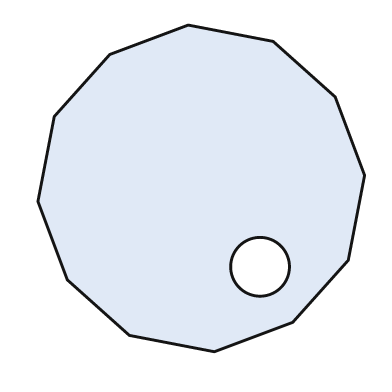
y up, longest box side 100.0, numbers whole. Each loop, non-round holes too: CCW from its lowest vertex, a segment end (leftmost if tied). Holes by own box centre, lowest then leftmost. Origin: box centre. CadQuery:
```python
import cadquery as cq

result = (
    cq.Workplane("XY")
    .moveTo(4.0, -50.0)
    .lineTo(28.0, -41.0)
    .lineTo(45.0, -22.0)
    .lineTo(50.0, 4.0)
    .lineTo(41.0, 28.0)
    .lineTo(22.0, 45.0)
    .lineTo(-4.0, 50.0)
    .lineTo(-28.0, 41.0)
    .lineTo(-45.0, 22.0)
    .lineTo(-50.0, -4.0)
    .lineTo(-41.0, -28.0)
    .lineTo(-22.0, -45.0)
    .close()
    .moveTo(18.0, -24.0)
    .circle(9.0)
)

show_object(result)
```